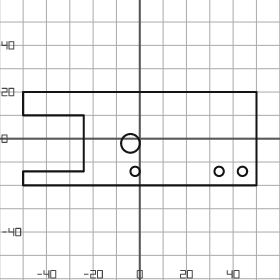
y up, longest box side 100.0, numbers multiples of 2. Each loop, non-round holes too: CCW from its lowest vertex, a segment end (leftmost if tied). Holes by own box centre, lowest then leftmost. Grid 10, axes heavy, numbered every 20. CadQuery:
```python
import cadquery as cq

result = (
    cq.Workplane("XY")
    .moveTo(-50.0, -20.0)
    .lineTo(50.0, -20.0)
    .lineTo(50.0, 20.0)
    .lineTo(-50.0, 20.0)
    .lineTo(-50.0, 10.0)
    .lineTo(-24.0, 10.0)
    .lineTo(-24.0, -14.0)
    .lineTo(-50.0, -14.0)
    .close()
    .moveTo(-2.0, -14.0)
    .circle(2.0)
    .moveTo(34.0, -14.0)
    .circle(2.0)
    .moveTo(44.0, -14.0)
    .circle(2.0)
    .moveTo(-4.0, -2.0)
    .circle(4.0)
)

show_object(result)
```